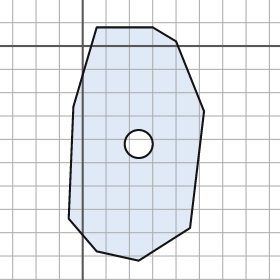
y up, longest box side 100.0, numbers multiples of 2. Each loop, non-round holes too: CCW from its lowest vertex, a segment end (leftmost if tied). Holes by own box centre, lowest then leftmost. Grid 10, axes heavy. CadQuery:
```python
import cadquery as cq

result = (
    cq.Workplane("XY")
    .moveTo(24.0, -92.0)
    .lineTo(46.0, -78.0)
    .lineTo(52.0, -28.0)
    .lineTo(40.0, 2.0)
    .lineTo(30.0, 8.0)
    .lineTo(6.0, 8.0)
    .lineTo(-4.0, -26.0)
    .lineTo(-6.0, -74.0)
    .lineTo(6.0, -88.0)
    .close()
    .moveTo(24.0, -42.0)
    .circle(6.0)
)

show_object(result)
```